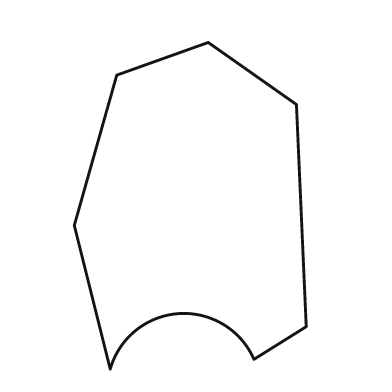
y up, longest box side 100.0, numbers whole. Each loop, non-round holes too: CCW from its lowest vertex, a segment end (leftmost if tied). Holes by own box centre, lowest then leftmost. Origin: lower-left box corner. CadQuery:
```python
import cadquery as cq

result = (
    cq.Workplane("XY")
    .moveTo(11.0, 0.0)
    .threePointArc((32.0, 17.0), (55.0, 3.0))
    .lineTo(71.0, 13.0)
    .lineTo(68.0, 81.0)
    .lineTo(41.0, 100.0)
    .lineTo(13.0, 90.0)
    .lineTo(0.0, 44.0)
    .close()
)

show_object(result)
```